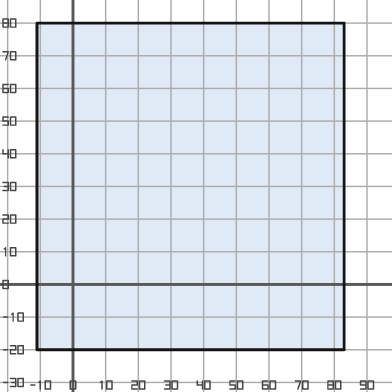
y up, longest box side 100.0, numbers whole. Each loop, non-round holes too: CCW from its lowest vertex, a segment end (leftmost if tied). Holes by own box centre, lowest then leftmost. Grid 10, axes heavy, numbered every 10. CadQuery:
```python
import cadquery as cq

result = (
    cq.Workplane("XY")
    .moveTo(-11.0, -20.0)
    .lineTo(83.0, -20.0)
    .lineTo(83.0, 80.0)
    .lineTo(-11.0, 80.0)
    .close()
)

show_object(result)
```